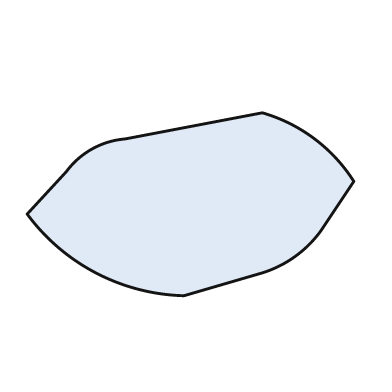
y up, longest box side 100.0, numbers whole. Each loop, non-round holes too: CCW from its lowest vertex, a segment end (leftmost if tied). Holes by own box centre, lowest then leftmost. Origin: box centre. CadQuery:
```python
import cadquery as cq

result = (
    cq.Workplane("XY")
    .moveTo(-2.0, -28.0)
    .lineTo(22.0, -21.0)
    .threePointArc((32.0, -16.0), (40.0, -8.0))
    .lineTo(50.0, 7.0)
    .threePointArc((38.0, 20.0), (22.0, 28.0))
    .lineTo(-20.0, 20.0)
    .threePointArc((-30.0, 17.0), (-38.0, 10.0))
    .lineTo(-50.0, -3.0)
    .threePointArc((-29.0, -21.0), (-2.0, -28.0))
    .close()
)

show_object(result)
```